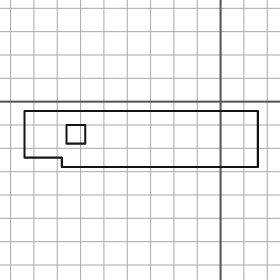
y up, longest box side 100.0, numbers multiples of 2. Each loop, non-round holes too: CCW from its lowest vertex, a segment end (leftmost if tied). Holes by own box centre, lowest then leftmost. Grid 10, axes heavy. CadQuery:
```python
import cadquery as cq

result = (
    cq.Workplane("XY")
    .moveTo(-68.0, -28.0)
    .lineTo(16.0, -28.0)
    .lineTo(16.0, -4.0)
    .lineTo(-84.0, -4.0)
    .lineTo(-84.0, -24.0)
    .lineTo(-68.0, -24.0)
    .close()
    .moveTo(-66.0, -18.0)
    .lineTo(-58.0, -18.0)
    .lineTo(-58.0, -10.0)
    .lineTo(-66.0, -10.0)
    .close()
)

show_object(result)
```